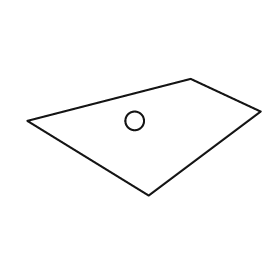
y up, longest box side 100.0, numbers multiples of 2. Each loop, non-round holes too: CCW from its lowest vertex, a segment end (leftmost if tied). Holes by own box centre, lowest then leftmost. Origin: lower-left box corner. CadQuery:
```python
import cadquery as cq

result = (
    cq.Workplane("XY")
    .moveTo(52.0, 0.0)
    .lineTo(100.0, 36.0)
    .lineTo(70.0, 50.0)
    .lineTo(0.0, 32.0)
    .close()
    .moveTo(46.0, 32.0)
    .circle(4.0)
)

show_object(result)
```